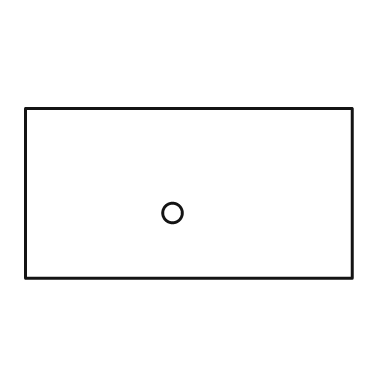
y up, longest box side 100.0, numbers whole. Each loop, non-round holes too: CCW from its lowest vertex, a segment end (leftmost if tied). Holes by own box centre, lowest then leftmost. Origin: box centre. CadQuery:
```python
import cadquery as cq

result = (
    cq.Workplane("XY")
    .moveTo(-50.0, -26.0)
    .lineTo(50.0, -26.0)
    .lineTo(50.0, 26.0)
    .lineTo(-50.0, 26.0)
    .close()
    .moveTo(-5.0, -6.0)
    .circle(3.0)
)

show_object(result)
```